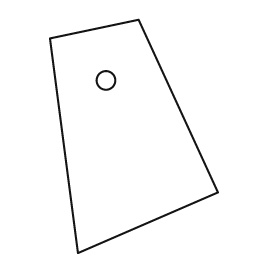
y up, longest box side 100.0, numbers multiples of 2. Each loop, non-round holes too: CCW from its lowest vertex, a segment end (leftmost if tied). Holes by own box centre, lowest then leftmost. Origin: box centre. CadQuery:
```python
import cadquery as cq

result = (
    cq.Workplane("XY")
    .moveTo(-24.0, -50.0)
    .lineTo(36.0, -24.0)
    .lineTo(2.0, 50.0)
    .lineTo(-36.0, 42.0)
    .close()
    .moveTo(-12.0, 24.0)
    .circle(4.0)
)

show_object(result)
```